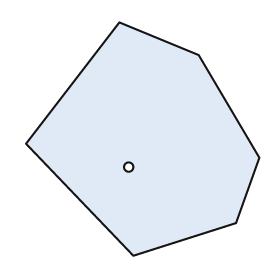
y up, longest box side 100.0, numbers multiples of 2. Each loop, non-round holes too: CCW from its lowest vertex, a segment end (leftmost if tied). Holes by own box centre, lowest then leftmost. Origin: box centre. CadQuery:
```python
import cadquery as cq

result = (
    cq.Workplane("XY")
    .moveTo(-4.0, -50.0)
    .lineTo(40.0, -36.0)
    .lineTo(50.0, -8.0)
    .lineTo(24.0, 36.0)
    .lineTo(-10.0, 50.0)
    .lineTo(-50.0, -2.0)
    .close()
    .moveTo(-6.0, -12.0)
    .circle(2.0)
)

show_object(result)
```